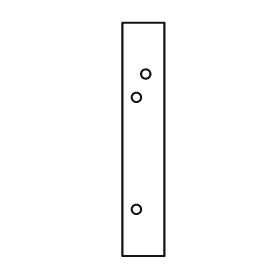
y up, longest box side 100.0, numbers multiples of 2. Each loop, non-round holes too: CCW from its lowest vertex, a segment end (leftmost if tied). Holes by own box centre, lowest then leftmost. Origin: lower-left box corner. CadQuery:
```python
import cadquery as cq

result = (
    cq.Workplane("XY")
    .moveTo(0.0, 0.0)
    .lineTo(18.0, 0.0)
    .lineTo(18.0, 100.0)
    .lineTo(0.0, 100.0)
    .close()
    .moveTo(6.0, 20.0)
    .circle(2.0)
    .moveTo(6.0, 68.0)
    .circle(2.0)
    .moveTo(10.0, 78.0)
    .circle(2.0)
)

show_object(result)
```